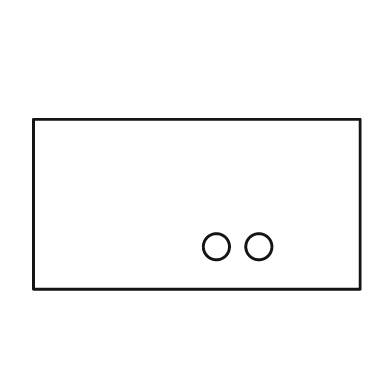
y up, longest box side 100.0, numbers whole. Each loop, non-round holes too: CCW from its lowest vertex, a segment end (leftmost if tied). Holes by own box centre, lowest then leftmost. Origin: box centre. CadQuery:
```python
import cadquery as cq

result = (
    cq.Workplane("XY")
    .moveTo(-50.0, -26.0)
    .lineTo(50.0, -26.0)
    .lineTo(50.0, 26.0)
    .lineTo(-50.0, 26.0)
    .close()
    .moveTo(6.0, -13.0)
    .circle(4.0)
    .moveTo(19.0, -13.0)
    .circle(4.0)
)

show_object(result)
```